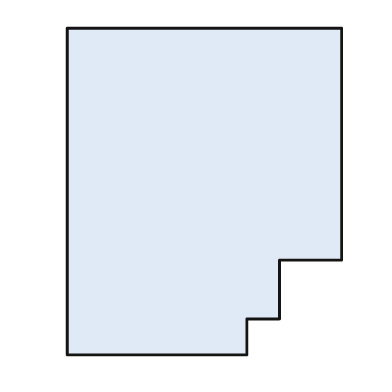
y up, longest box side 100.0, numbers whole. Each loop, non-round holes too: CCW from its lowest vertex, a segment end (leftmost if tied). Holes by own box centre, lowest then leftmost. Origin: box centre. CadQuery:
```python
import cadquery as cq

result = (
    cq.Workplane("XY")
    .moveTo(-42.0, -50.0)
    .lineTo(13.0, -50.0)
    .lineTo(13.0, -39.0)
    .lineTo(23.0, -39.0)
    .lineTo(23.0, -21.0)
    .lineTo(42.0, -21.0)
    .lineTo(42.0, 50.0)
    .lineTo(-42.0, 50.0)
    .close()
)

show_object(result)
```